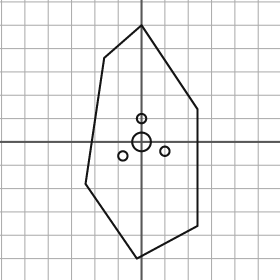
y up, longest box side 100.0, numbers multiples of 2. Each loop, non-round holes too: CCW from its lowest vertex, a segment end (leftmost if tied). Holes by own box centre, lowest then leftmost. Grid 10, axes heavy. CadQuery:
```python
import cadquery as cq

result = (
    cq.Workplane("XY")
    .moveTo(-2.0, -50.0)
    .lineTo(24.0, -36.0)
    .lineTo(24.0, 14.0)
    .lineTo(0.0, 50.0)
    .lineTo(-16.0, 36.0)
    .lineTo(-24.0, -18.0)
    .close()
    .moveTo(-8.0, -6.0)
    .circle(2.0)
    .moveTo(10.0, -4.0)
    .circle(2.0)
    .moveTo(0.0, 0.0)
    .circle(4.0)
    .moveTo(0.0, 10.0)
    .circle(2.0)
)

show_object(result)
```